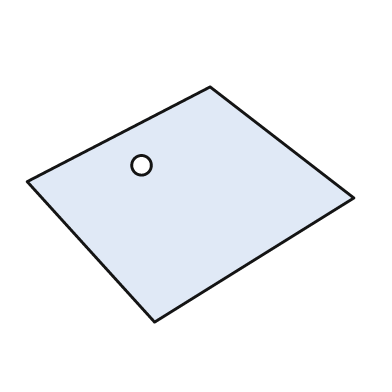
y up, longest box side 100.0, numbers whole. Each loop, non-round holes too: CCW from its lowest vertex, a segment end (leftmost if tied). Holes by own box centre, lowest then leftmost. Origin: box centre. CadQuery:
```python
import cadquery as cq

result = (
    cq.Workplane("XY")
    .moveTo(-11.0, -36.0)
    .lineTo(50.0, 2.0)
    .lineTo(6.0, 36.0)
    .lineTo(-50.0, 7.0)
    .close()
    .moveTo(-15.0, 12.0)
    .circle(3.0)
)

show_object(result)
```